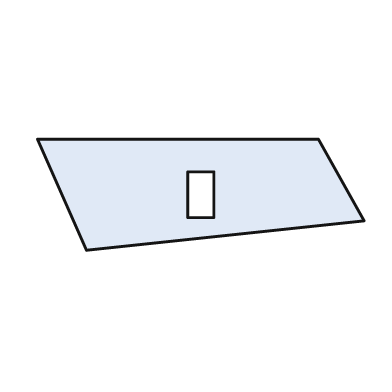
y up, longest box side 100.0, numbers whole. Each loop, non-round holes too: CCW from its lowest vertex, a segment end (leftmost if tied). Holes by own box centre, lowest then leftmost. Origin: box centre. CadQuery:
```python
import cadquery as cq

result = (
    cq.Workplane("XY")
    .moveTo(-35.0, -17.0)
    .lineTo(50.0, -8.0)
    .lineTo(36.0, 17.0)
    .lineTo(-50.0, 17.0)
    .close()
    .moveTo(-4.0, -7.0)
    .lineTo(4.0, -7.0)
    .lineTo(4.0, 7.0)
    .lineTo(-4.0, 7.0)
    .close()
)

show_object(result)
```